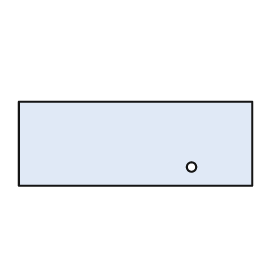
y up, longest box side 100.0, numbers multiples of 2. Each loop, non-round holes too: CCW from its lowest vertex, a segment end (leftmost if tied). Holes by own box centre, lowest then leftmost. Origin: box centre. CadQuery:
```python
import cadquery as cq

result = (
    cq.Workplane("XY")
    .moveTo(-50.0, -18.0)
    .lineTo(50.0, -18.0)
    .lineTo(50.0, 18.0)
    .lineTo(-50.0, 18.0)
    .close()
    .moveTo(24.0, -10.0)
    .circle(2.0)
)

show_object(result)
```